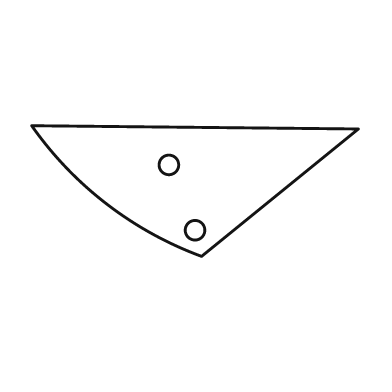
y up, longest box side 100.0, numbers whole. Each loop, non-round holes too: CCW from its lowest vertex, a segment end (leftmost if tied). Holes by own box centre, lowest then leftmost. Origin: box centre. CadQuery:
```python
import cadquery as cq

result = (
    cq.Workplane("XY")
    .moveTo(2.0, -20.0)
    .lineTo(50.0, 19.0)
    .lineTo(-50.0, 20.0)
    .threePointArc((-27.0, -4.0), (2.0, -20.0))
    .close()
    .moveTo(0.0, -12.0)
    .circle(3.0)
    .moveTo(-8.0, 8.0)
    .circle(3.0)
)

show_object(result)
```